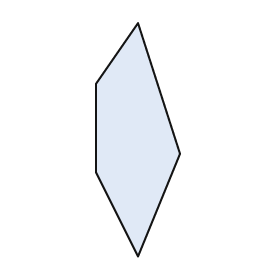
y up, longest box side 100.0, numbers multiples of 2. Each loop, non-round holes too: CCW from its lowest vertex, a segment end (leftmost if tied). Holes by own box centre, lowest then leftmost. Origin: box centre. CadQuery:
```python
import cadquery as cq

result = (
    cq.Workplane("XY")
    .moveTo(0.0, -50.0)
    .lineTo(18.0, -6.0)
    .lineTo(0.0, 50.0)
    .lineTo(-18.0, 24.0)
    .lineTo(-18.0, -14.0)
    .close()
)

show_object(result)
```